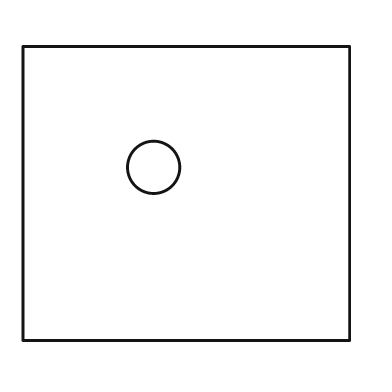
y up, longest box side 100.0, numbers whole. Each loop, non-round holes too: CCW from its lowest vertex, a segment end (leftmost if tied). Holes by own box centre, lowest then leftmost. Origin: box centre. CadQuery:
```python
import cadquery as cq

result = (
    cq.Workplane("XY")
    .moveTo(-50.0, -45.0)
    .lineTo(50.0, -45.0)
    .lineTo(50.0, 45.0)
    .lineTo(-50.0, 45.0)
    .close()
    .moveTo(-10.0, 8.0)
    .circle(8.0)
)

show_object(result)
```